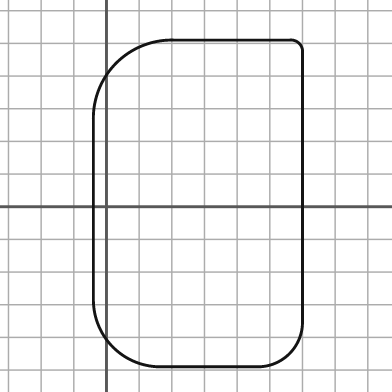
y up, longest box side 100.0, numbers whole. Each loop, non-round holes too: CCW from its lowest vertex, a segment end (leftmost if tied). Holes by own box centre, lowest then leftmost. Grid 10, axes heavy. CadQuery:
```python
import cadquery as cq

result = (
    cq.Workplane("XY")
    .moveTo(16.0, -49.0)
    .lineTo(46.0, -49.0)
    .threePointArc((56.0, -45.0), (60.0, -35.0))
    .lineTo(60.0, 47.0)
    .threePointArc((59.0, 50.0), (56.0, 51.0))
    .lineTo(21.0, 51.0)
    .threePointArc((3.0, 44.0), (-4.0, 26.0))
    .lineTo(-4.0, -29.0)
    .threePointArc((2.0, -43.0), (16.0, -49.0))
    .close()
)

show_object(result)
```